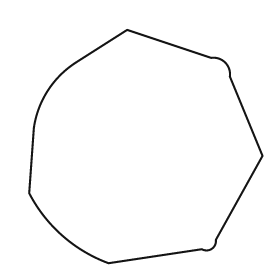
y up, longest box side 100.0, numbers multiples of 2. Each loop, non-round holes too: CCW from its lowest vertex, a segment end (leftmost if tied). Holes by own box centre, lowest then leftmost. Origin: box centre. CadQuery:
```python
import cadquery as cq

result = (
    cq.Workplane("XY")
    .moveTo(-16.0, -50.0)
    .lineTo(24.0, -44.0)
    .threePointArc((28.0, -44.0), (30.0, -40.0))
    .lineTo(50.0, -4.0)
    .lineTo(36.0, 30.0)
    .threePointArc((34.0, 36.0), (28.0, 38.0))
    .lineTo(-8.0, 50.0)
    .lineTo(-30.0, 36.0)
    .threePointArc((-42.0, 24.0), (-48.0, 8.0))
    .lineTo(-50.0, -20.0)
    .threePointArc((-36.0, -38.0), (-16.0, -50.0))
    .close()
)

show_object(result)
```